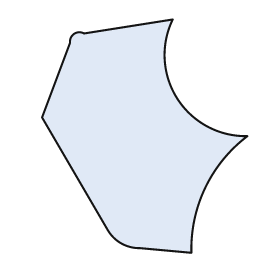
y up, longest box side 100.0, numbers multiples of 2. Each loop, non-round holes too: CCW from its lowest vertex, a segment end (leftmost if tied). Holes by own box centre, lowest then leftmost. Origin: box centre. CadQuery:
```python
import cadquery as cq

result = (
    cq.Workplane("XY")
    .moveTo(20.0, -50.0)
    .threePointArc((26.0, -22.0), (44.0, 0.0))
    .threePointArc((14.0, 16.0), (12.0, 50.0))
    .lineTo(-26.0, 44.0)
    .threePointArc((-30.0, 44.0), (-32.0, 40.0))
    .lineTo(-44.0, 8.0)
    .lineTo(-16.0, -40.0)
    .threePointArc((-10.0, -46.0), (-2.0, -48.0))
    .close()
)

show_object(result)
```